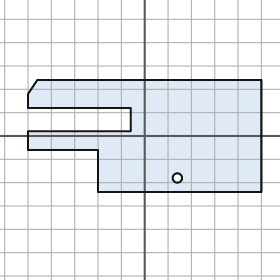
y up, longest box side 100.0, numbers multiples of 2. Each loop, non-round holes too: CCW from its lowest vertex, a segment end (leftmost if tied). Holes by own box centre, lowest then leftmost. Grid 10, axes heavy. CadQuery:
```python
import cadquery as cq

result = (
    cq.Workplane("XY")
    .moveTo(-20.0, -24.0)
    .lineTo(50.0, -24.0)
    .lineTo(50.0, 24.0)
    .lineTo(-46.0, 24.0)
    .lineTo(-50.0, 18.0)
    .lineTo(-50.0, 12.0)
    .lineTo(-6.0, 12.0)
    .lineTo(-6.0, 2.0)
    .lineTo(-50.0, 2.0)
    .lineTo(-50.0, -6.0)
    .lineTo(-20.0, -6.0)
    .close()
    .moveTo(14.0, -18.0)
    .circle(2.0)
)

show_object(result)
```